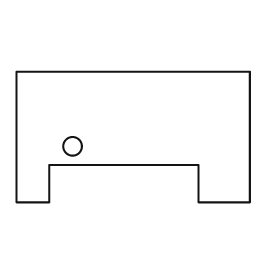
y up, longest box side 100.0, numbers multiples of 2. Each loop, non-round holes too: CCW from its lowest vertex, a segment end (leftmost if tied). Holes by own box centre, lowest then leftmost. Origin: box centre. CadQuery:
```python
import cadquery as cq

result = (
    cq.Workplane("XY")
    .moveTo(-50.0, -28.0)
    .lineTo(-36.0, -28.0)
    .lineTo(-36.0, -12.0)
    .lineTo(28.0, -12.0)
    .lineTo(28.0, -28.0)
    .lineTo(50.0, -28.0)
    .lineTo(50.0, 28.0)
    .lineTo(-50.0, 28.0)
    .close()
    .moveTo(-26.0, -4.0)
    .circle(4.0)
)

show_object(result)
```